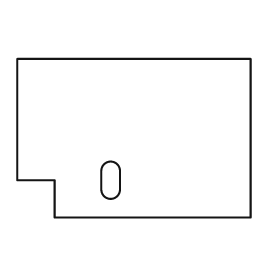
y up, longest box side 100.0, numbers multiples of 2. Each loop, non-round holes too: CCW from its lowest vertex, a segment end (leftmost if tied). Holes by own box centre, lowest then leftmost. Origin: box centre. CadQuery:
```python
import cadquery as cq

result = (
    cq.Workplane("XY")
    .moveTo(-34.0, -34.0)
    .lineTo(50.0, -34.0)
    .lineTo(50.0, 34.0)
    .lineTo(-50.0, 34.0)
    .lineTo(-50.0, -18.0)
    .lineTo(-34.0, -18.0)
    .close()
    .moveTo(-14.0, -22.0)
    .threePointArc((-10.0, -26.0), (-6.0, -22.0))
    .lineTo(-6.0, -14.0)
    .threePointArc((-10.0, -10.0), (-14.0, -14.0))
    .close()
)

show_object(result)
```